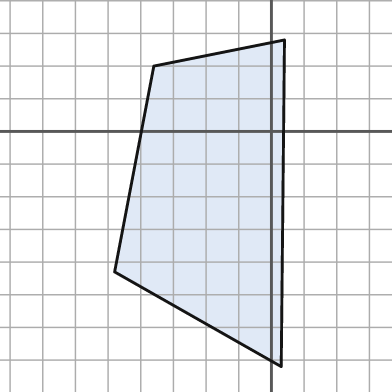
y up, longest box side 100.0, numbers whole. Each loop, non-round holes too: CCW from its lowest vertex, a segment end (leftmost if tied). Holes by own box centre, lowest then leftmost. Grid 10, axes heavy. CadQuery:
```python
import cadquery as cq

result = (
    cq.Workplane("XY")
    .moveTo(3.0, -72.0)
    .lineTo(4.0, 28.0)
    .lineTo(-36.0, 20.0)
    .lineTo(-48.0, -43.0)
    .close()
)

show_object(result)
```